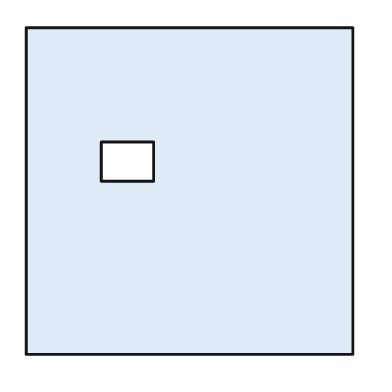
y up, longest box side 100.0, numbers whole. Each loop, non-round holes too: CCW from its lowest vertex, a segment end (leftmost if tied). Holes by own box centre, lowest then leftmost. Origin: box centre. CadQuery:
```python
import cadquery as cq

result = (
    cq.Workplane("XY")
    .moveTo(-50.0, -50.0)
    .lineTo(50.0, -50.0)
    .lineTo(50.0, 50.0)
    .lineTo(-50.0, 50.0)
    .close()
    .moveTo(-27.0, 3.0)
    .lineTo(-11.0, 3.0)
    .lineTo(-11.0, 15.0)
    .lineTo(-27.0, 15.0)
    .close()
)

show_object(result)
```